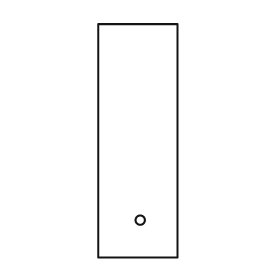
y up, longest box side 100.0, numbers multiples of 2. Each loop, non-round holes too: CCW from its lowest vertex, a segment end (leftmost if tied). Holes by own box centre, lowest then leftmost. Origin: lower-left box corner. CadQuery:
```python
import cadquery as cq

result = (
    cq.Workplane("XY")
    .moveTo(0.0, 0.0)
    .lineTo(34.0, 0.0)
    .lineTo(34.0, 100.0)
    .lineTo(0.0, 100.0)
    .close()
    .moveTo(18.0, 16.0)
    .circle(2.0)
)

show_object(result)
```